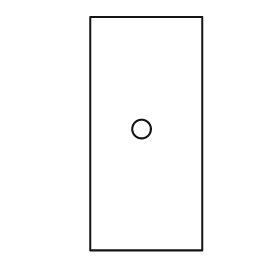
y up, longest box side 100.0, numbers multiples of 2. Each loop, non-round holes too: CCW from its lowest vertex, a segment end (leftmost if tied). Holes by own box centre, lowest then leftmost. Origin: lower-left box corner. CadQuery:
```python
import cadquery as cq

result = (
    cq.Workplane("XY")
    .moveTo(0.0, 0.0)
    .lineTo(48.0, 0.0)
    .lineTo(48.0, 100.0)
    .lineTo(0.0, 100.0)
    .close()
    .moveTo(22.0, 52.0)
    .circle(4.0)
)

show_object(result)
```